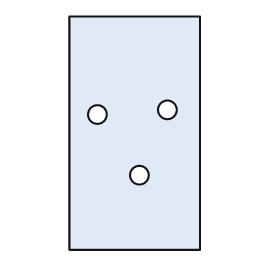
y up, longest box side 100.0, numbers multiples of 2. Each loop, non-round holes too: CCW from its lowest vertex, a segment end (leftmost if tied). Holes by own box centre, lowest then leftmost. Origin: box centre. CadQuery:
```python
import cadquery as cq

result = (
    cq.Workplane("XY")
    .moveTo(-28.0, -50.0)
    .lineTo(28.0, -50.0)
    .lineTo(28.0, 50.0)
    .lineTo(-28.0, 50.0)
    .close()
    .moveTo(2.0, -18.0)
    .circle(4.0)
    .moveTo(-16.0, 8.0)
    .circle(4.0)
    .moveTo(14.0, 10.0)
    .circle(4.0)
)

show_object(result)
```